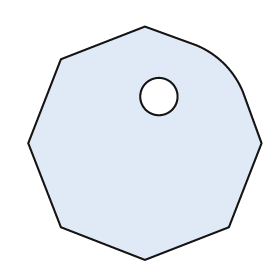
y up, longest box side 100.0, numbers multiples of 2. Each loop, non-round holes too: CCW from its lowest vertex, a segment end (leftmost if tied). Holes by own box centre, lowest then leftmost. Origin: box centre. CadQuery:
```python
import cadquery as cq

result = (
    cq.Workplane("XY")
    .moveTo(0.0, -50.0)
    .lineTo(36.0, -36.0)
    .lineTo(50.0, 0.0)
    .lineTo(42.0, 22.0)
    .threePointArc((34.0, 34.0), (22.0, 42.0))
    .lineTo(0.0, 50.0)
    .lineTo(-36.0, 36.0)
    .lineTo(-50.0, 0.0)
    .lineTo(-36.0, -36.0)
    .close()
    .moveTo(6.0, 20.0)
    .circle(8.0)
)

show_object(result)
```